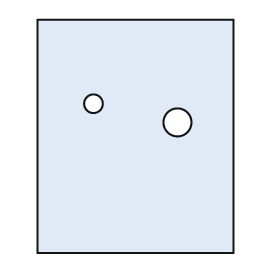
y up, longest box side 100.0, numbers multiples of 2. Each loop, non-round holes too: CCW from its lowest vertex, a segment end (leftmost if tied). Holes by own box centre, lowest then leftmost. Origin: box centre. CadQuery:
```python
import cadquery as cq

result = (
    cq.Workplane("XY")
    .moveTo(-42.0, -50.0)
    .lineTo(42.0, -50.0)
    .lineTo(42.0, 50.0)
    .lineTo(-42.0, 50.0)
    .close()
    .moveTo(18.0, 6.0)
    .circle(6.0)
    .moveTo(-18.0, 14.0)
    .circle(4.0)
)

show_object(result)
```